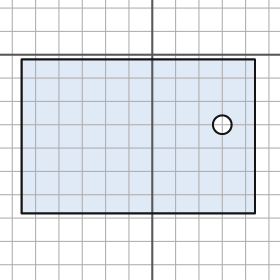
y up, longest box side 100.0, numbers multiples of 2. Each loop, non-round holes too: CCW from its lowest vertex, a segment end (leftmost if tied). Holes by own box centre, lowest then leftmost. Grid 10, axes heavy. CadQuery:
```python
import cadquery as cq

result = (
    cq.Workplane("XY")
    .moveTo(-56.0, -68.0)
    .lineTo(44.0, -68.0)
    .lineTo(44.0, -2.0)
    .lineTo(-56.0, -2.0)
    .close()
    .moveTo(30.0, -30.0)
    .circle(4.0)
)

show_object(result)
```